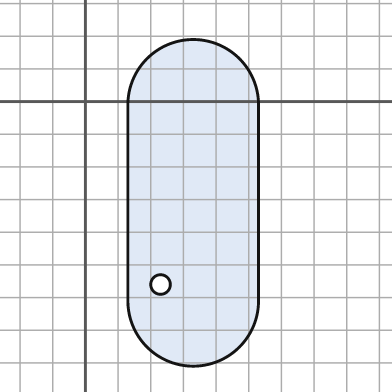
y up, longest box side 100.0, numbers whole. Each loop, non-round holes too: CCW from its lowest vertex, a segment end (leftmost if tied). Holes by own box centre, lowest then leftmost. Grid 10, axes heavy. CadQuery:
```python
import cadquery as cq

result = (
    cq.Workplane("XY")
    .moveTo(13.0, -61.0)
    .threePointArc((33.0, -81.0), (53.0, -61.0))
    .lineTo(53.0, -1.0)
    .threePointArc((33.0, 19.0), (13.0, -1.0))
    .close()
    .moveTo(23.0, -56.0)
    .circle(3.0)
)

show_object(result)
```